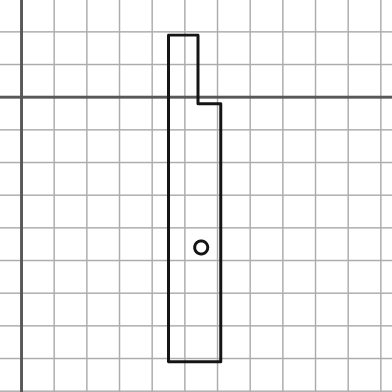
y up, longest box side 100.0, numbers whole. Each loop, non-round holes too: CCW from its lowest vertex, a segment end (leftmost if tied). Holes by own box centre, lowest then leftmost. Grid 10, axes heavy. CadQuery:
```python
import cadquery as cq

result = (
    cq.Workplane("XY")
    .moveTo(45.0, -81.0)
    .lineTo(61.0, -81.0)
    .lineTo(61.0, -2.0)
    .lineTo(54.0, -2.0)
    .lineTo(54.0, 19.0)
    .lineTo(45.0, 19.0)
    .close()
    .moveTo(55.0, -46.0)
    .circle(2.0)
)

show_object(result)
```